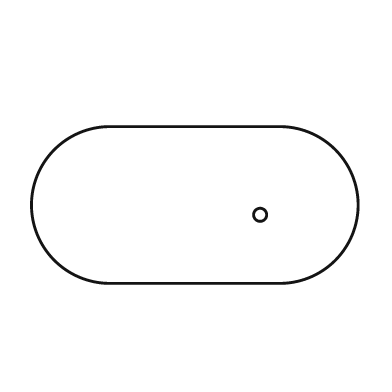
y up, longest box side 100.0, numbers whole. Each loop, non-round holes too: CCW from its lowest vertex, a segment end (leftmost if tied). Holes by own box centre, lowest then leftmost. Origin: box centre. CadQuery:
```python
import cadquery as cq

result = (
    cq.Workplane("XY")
    .moveTo(-26.0, -24.0)
    .lineTo(26.0, -24.0)
    .threePointArc((50.0, 0.0), (26.0, 24.0))
    .lineTo(-26.0, 24.0)
    .threePointArc((-50.0, 0.0), (-26.0, -24.0))
    .close()
    .moveTo(20.0, -3.0)
    .circle(2.0)
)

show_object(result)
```